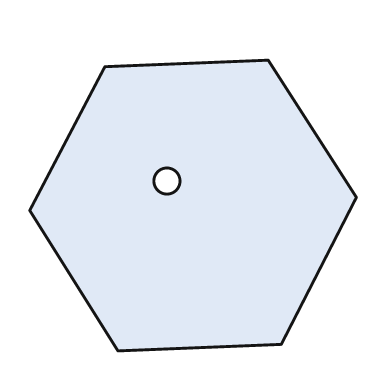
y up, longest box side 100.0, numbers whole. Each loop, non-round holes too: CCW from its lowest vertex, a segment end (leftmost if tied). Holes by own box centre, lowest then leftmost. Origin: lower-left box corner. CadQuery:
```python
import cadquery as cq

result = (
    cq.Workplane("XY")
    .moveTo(27.0, 0.0)
    .lineTo(77.0, 2.0)
    .lineTo(100.0, 47.0)
    .lineTo(73.0, 89.0)
    .lineTo(23.0, 87.0)
    .lineTo(0.0, 43.0)
    .close()
    .moveTo(42.0, 52.0)
    .circle(4.0)
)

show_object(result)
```